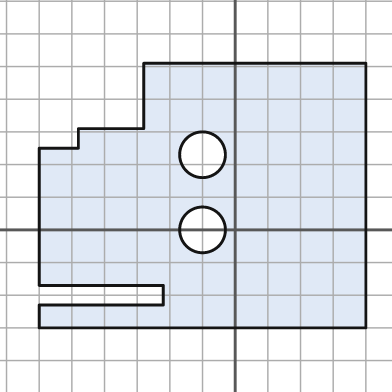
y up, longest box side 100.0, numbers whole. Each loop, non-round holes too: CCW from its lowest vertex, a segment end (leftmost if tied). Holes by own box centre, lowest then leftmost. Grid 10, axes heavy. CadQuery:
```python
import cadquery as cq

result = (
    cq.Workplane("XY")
    .moveTo(-60.0, -30.0)
    .lineTo(40.0, -30.0)
    .lineTo(40.0, 51.0)
    .lineTo(-28.0, 51.0)
    .lineTo(-28.0, 31.0)
    .lineTo(-48.0, 31.0)
    .lineTo(-48.0, 25.0)
    .lineTo(-60.0, 25.0)
    .lineTo(-60.0, -17.0)
    .lineTo(-22.0, -17.0)
    .lineTo(-22.0, -23.0)
    .lineTo(-60.0, -23.0)
    .close()
    .moveTo(-10.0, 0.0)
    .circle(7.0)
    .moveTo(-10.0, 23.0)
    .circle(7.0)
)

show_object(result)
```